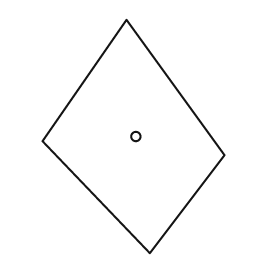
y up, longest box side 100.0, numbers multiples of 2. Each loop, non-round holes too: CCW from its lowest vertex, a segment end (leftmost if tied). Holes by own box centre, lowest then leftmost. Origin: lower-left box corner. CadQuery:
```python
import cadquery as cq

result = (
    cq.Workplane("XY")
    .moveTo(46.0, 0.0)
    .lineTo(78.0, 42.0)
    .lineTo(36.0, 100.0)
    .lineTo(0.0, 48.0)
    .close()
    .moveTo(40.0, 50.0)
    .circle(2.0)
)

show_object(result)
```